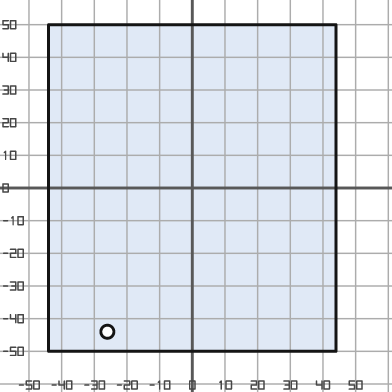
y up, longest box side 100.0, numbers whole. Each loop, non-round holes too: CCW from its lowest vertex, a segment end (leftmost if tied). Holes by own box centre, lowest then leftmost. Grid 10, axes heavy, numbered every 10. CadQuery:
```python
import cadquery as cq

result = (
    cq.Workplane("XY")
    .moveTo(-44.0, -50.0)
    .lineTo(44.0, -50.0)
    .lineTo(44.0, 50.0)
    .lineTo(-44.0, 50.0)
    .close()
    .moveTo(-26.0, -44.0)
    .circle(2.0)
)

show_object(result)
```